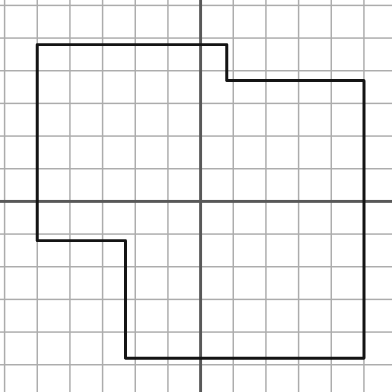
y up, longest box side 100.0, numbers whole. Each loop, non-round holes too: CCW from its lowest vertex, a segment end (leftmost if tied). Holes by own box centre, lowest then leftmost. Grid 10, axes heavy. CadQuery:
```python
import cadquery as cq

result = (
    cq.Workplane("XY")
    .moveTo(-23.0, -48.0)
    .lineTo(50.0, -48.0)
    .lineTo(50.0, 37.0)
    .lineTo(8.0, 37.0)
    .lineTo(8.0, 48.0)
    .lineTo(-50.0, 48.0)
    .lineTo(-50.0, -12.0)
    .lineTo(-23.0, -12.0)
    .close()
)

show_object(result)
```